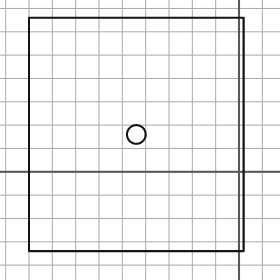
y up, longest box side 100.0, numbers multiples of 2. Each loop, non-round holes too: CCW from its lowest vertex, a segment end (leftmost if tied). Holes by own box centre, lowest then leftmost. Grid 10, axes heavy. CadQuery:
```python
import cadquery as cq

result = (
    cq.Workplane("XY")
    .moveTo(-90.0, -34.0)
    .lineTo(2.0, -34.0)
    .lineTo(2.0, 66.0)
    .lineTo(-90.0, 66.0)
    .close()
    .moveTo(-44.0, 16.0)
    .circle(4.0)
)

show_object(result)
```